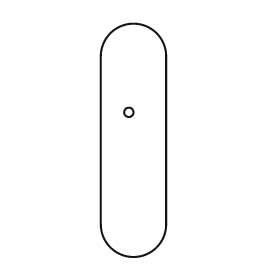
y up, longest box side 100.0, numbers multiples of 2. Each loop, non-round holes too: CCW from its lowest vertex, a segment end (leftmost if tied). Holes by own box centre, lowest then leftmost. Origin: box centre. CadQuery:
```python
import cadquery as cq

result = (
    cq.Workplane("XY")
    .moveTo(-14.0, -36.0)
    .threePointArc((0.0, -50.0), (14.0, -36.0))
    .lineTo(14.0, 36.0)
    .threePointArc((0.0, 50.0), (-14.0, 36.0))
    .close()
    .moveTo(-2.0, 12.0)
    .circle(2.0)
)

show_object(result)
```